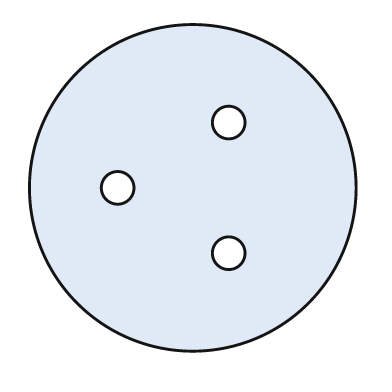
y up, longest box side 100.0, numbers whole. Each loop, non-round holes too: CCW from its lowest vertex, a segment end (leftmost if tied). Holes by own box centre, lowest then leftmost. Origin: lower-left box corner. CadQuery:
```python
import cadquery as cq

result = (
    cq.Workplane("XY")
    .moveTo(50.0, 50.0)
    .circle(50.0)
    .moveTo(61.0, 30.0)
    .circle(5.0)
    .moveTo(27.0, 50.0)
    .circle(5.0)
    .moveTo(61.0, 70.0)
    .circle(5.0)
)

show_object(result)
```